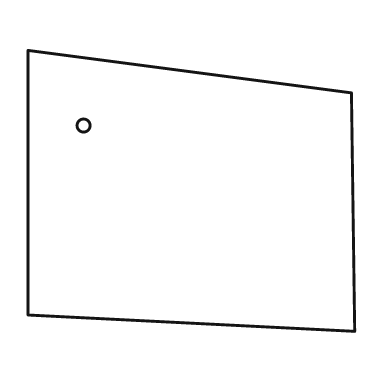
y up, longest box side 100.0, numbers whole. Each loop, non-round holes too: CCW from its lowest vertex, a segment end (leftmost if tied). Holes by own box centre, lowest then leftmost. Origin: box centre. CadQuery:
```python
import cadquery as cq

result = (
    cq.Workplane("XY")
    .moveTo(50.0, -43.0)
    .lineTo(49.0, 30.0)
    .lineTo(-50.0, 43.0)
    .lineTo(-50.0, -38.0)
    .close()
    .moveTo(-33.0, 20.0)
    .circle(2.0)
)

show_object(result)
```